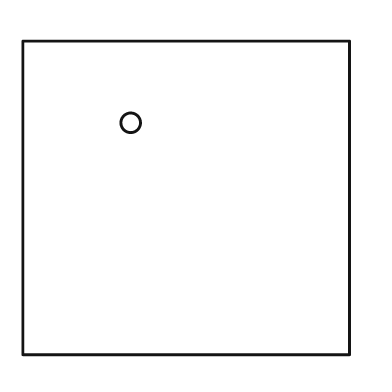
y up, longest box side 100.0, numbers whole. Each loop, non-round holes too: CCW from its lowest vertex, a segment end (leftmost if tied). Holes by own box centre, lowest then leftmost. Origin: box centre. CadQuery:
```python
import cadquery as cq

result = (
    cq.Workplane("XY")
    .moveTo(-50.0, -48.0)
    .lineTo(50.0, -48.0)
    .lineTo(50.0, 48.0)
    .lineTo(-50.0, 48.0)
    .close()
    .moveTo(-17.0, 23.0)
    .circle(3.0)
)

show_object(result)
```